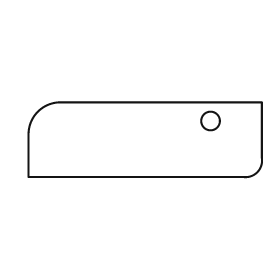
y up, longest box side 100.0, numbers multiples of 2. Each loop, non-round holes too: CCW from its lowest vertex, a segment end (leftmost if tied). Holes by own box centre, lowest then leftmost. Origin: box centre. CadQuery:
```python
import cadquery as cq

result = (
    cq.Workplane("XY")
    .moveTo(-50.0, -16.0)
    .lineTo(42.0, -16.0)
    .threePointArc((48.0, -14.0), (50.0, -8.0))
    .lineTo(50.0, 16.0)
    .lineTo(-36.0, 16.0)
    .threePointArc((-46.0, 12.0), (-50.0, 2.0))
    .close()
    .moveTo(28.0, 8.0)
    .circle(4.0)
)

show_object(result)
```